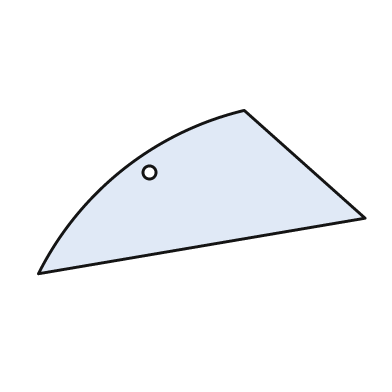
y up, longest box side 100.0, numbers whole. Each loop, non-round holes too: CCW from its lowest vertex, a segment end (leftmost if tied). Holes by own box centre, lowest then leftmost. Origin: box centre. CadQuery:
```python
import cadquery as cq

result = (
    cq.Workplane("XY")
    .moveTo(-50.0, -25.0)
    .lineTo(50.0, -8.0)
    .lineTo(13.0, 25.0)
    .threePointArc((-24.0, 7.0), (-50.0, -25.0))
    .close()
    .moveTo(-16.0, 6.0)
    .circle(2.0)
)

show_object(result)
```